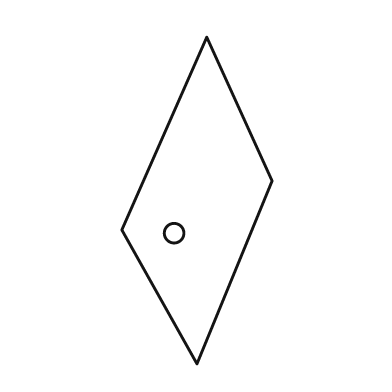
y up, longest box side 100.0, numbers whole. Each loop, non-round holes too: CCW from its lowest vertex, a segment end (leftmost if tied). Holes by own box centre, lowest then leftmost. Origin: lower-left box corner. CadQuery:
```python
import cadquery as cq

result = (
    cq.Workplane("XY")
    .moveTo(23.0, 0.0)
    .lineTo(46.0, 56.0)
    .lineTo(26.0, 100.0)
    .lineTo(0.0, 41.0)
    .close()
    .moveTo(16.0, 40.0)
    .circle(3.0)
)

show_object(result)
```